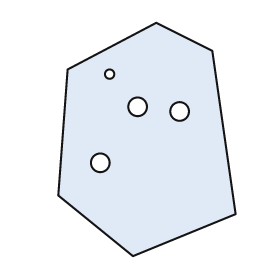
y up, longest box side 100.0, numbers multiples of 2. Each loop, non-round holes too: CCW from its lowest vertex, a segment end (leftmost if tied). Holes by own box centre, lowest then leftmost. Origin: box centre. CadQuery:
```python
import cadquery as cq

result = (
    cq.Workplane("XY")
    .moveTo(-6.0, -50.0)
    .lineTo(38.0, -32.0)
    .lineTo(28.0, 38.0)
    .lineTo(4.0, 50.0)
    .lineTo(-34.0, 30.0)
    .lineTo(-38.0, -24.0)
    .close()
    .moveTo(-20.0, -10.0)
    .circle(4.0)
    .moveTo(14.0, 12.0)
    .circle(4.0)
    .moveTo(-4.0, 14.0)
    .circle(4.0)
    .moveTo(-16.0, 28.0)
    .circle(2.0)
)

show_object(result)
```